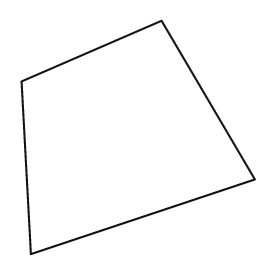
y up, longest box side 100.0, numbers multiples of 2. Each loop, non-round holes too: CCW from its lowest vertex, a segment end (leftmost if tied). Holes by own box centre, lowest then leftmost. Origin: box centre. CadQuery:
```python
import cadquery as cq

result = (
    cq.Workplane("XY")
    .moveTo(-46.0, -50.0)
    .lineTo(50.0, -18.0)
    .lineTo(10.0, 50.0)
    .lineTo(-50.0, 24.0)
    .close()
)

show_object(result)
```